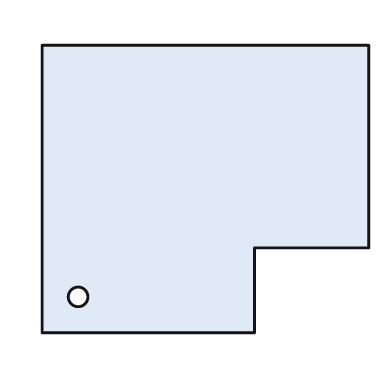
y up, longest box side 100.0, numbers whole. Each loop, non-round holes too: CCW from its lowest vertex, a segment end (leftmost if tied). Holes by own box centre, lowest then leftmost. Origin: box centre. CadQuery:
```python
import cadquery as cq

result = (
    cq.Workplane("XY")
    .moveTo(-50.0, -44.0)
    .lineTo(15.0, -44.0)
    .lineTo(15.0, -18.0)
    .lineTo(50.0, -18.0)
    .lineTo(50.0, 44.0)
    .lineTo(-50.0, 44.0)
    .close()
    .moveTo(-39.0, -33.0)
    .circle(3.0)
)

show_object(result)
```